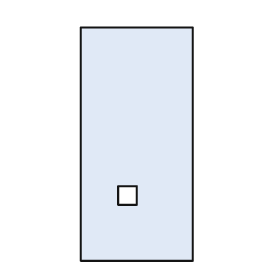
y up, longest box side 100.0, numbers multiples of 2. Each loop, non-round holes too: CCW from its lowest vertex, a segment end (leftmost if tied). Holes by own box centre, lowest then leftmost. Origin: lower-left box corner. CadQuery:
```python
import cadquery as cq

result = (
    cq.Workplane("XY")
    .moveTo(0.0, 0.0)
    .lineTo(48.0, 0.0)
    .lineTo(48.0, 100.0)
    .lineTo(0.0, 100.0)
    .close()
    .moveTo(16.0, 24.0)
    .lineTo(24.0, 24.0)
    .lineTo(24.0, 32.0)
    .lineTo(16.0, 32.0)
    .close()
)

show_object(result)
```